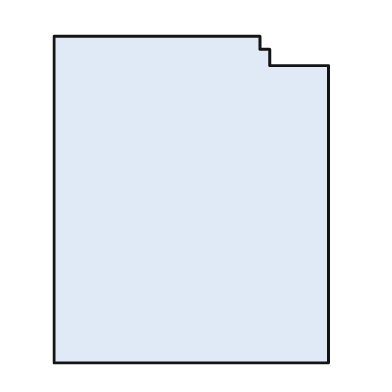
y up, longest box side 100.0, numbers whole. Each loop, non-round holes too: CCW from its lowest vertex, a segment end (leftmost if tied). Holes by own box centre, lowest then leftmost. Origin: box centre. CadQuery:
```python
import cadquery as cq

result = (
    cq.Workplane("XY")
    .moveTo(-42.0, -50.0)
    .lineTo(42.0, -50.0)
    .lineTo(42.0, 41.0)
    .lineTo(24.0, 41.0)
    .lineTo(24.0, 46.0)
    .lineTo(21.0, 46.0)
    .lineTo(21.0, 50.0)
    .lineTo(-42.0, 50.0)
    .close()
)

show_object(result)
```